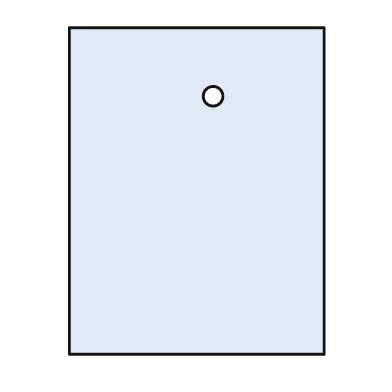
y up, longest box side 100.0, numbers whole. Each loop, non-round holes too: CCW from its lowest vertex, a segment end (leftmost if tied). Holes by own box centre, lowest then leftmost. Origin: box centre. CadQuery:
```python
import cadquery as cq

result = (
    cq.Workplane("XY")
    .moveTo(-39.0, -50.0)
    .lineTo(39.0, -50.0)
    .lineTo(39.0, 50.0)
    .lineTo(-39.0, 50.0)
    .close()
    .moveTo(5.0, 29.0)
    .circle(3.0)
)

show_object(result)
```